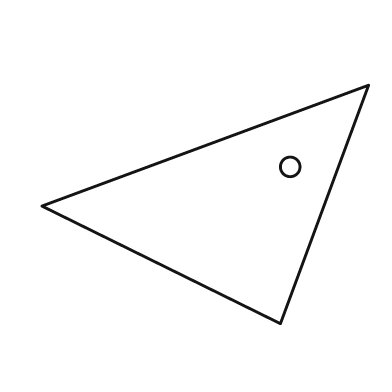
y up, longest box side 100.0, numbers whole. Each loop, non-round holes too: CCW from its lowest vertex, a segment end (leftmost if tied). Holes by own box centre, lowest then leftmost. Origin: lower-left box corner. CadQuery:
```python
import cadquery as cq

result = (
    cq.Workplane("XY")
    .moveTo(73.0, 0.0)
    .lineTo(100.0, 73.0)
    .lineTo(0.0, 36.0)
    .close()
    .moveTo(76.0, 48.0)
    .circle(3.0)
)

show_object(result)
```